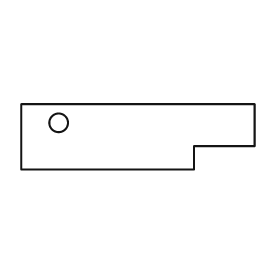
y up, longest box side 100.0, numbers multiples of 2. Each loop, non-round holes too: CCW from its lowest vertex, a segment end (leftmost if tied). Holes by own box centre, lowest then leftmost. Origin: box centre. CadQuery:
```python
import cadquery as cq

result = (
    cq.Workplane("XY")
    .moveTo(-50.0, -14.0)
    .lineTo(24.0, -14.0)
    .lineTo(24.0, -4.0)
    .lineTo(50.0, -4.0)
    .lineTo(50.0, 14.0)
    .lineTo(-50.0, 14.0)
    .close()
    .moveTo(-34.0, 6.0)
    .circle(4.0)
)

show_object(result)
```